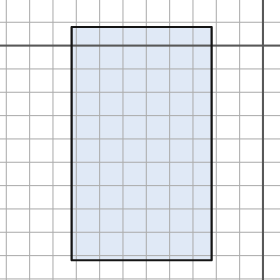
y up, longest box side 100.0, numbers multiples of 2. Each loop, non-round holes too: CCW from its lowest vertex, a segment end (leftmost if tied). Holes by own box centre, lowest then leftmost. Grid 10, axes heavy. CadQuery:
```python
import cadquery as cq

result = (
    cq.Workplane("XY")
    .moveTo(-82.0, -92.0)
    .lineTo(-22.0, -92.0)
    .lineTo(-22.0, 8.0)
    .lineTo(-82.0, 8.0)
    .close()
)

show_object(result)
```